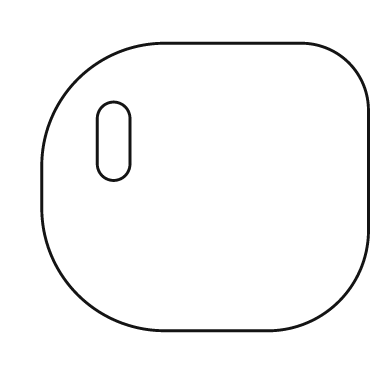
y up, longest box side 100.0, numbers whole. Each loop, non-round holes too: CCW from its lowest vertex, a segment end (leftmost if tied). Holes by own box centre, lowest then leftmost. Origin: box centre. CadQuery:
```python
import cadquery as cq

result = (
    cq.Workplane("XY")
    .moveTo(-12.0, -44.0)
    .lineTo(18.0, -44.0)
    .threePointArc((41.0, -35.0), (50.0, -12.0))
    .lineTo(50.0, 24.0)
    .threePointArc((44.0, 38.0), (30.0, 44.0))
    .lineTo(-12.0, 44.0)
    .threePointArc((-39.0, 33.0), (-50.0, 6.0))
    .lineTo(-50.0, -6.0)
    .threePointArc((-39.0, -33.0), (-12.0, -44.0))
    .close()
    .moveTo(-33.0, 7.0)
    .threePointArc((-28.0, 2.0), (-23.0, 7.0))
    .lineTo(-23.0, 21.0)
    .threePointArc((-28.0, 26.0), (-33.0, 21.0))
    .close()
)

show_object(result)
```